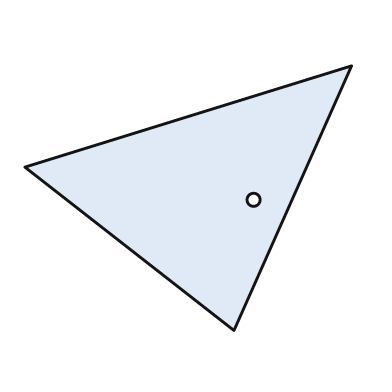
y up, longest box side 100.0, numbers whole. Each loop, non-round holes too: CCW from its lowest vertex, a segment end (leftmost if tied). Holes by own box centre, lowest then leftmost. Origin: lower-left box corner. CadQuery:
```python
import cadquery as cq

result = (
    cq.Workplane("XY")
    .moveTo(64.0, 0.0)
    .lineTo(100.0, 81.0)
    .lineTo(0.0, 50.0)
    .close()
    .moveTo(70.0, 40.0)
    .circle(2.0)
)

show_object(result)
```